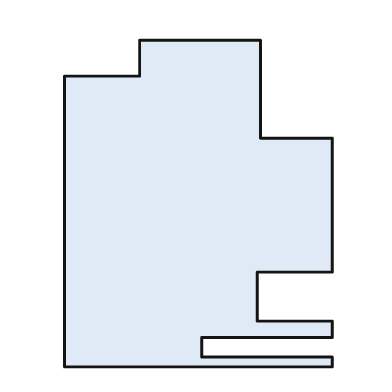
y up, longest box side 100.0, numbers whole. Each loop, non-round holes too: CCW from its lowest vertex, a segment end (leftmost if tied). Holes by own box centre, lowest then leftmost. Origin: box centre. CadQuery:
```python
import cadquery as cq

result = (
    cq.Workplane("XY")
    .moveTo(-41.0, -50.0)
    .lineTo(41.0, -50.0)
    .lineTo(41.0, -47.0)
    .lineTo(1.0, -47.0)
    .lineTo(1.0, -41.0)
    .lineTo(41.0, -41.0)
    .lineTo(41.0, -36.0)
    .lineTo(18.0, -36.0)
    .lineTo(18.0, -21.0)
    .lineTo(41.0, -21.0)
    .lineTo(41.0, 20.0)
    .lineTo(19.0, 20.0)
    .lineTo(19.0, 50.0)
    .lineTo(-18.0, 50.0)
    .lineTo(-18.0, 39.0)
    .lineTo(-41.0, 39.0)
    .close()
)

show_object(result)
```